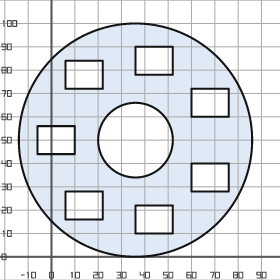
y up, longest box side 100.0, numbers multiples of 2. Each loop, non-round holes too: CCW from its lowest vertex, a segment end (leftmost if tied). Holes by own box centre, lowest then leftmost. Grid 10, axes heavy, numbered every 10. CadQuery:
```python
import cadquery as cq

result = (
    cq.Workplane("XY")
    .moveTo(36.0, 50.0)
    .circle(50.0)
    .moveTo(36.0, 10.0)
    .lineTo(52.0, 10.0)
    .lineTo(52.0, 22.0)
    .lineTo(36.0, 22.0)
    .close()
    .moveTo(6.0, 16.0)
    .lineTo(22.0, 16.0)
    .lineTo(22.0, 28.0)
    .lineTo(6.0, 28.0)
    .close()
    .moveTo(60.0, 28.0)
    .lineTo(76.0, 28.0)
    .lineTo(76.0, 40.0)
    .lineTo(60.0, 40.0)
    .close()
    .moveTo(-6.0, 44.0)
    .lineTo(10.0, 44.0)
    .lineTo(10.0, 56.0)
    .lineTo(-6.0, 56.0)
    .close()
    .moveTo(36.0, 50.0)
    .circle(16.0)
    .moveTo(60.0, 60.0)
    .lineTo(76.0, 60.0)
    .lineTo(76.0, 72.0)
    .lineTo(60.0, 72.0)
    .close()
    .moveTo(6.0, 72.0)
    .lineTo(22.0, 72.0)
    .lineTo(22.0, 84.0)
    .lineTo(6.0, 84.0)
    .close()
    .moveTo(36.0, 78.0)
    .lineTo(52.0, 78.0)
    .lineTo(52.0, 90.0)
    .lineTo(36.0, 90.0)
    .close()
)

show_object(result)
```